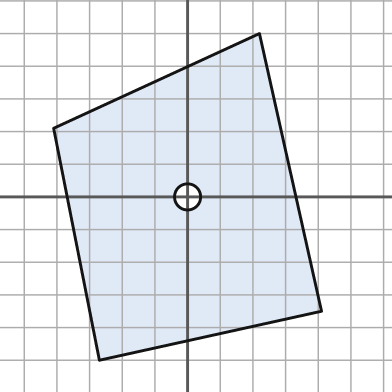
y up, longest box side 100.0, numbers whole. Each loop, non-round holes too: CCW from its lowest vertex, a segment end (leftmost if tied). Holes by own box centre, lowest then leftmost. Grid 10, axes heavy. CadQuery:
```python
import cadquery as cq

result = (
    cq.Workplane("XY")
    .moveTo(-27.0, -50.0)
    .lineTo(41.0, -35.0)
    .lineTo(22.0, 50.0)
    .lineTo(-41.0, 21.0)
    .close()
    .moveTo(0.0, 0.0)
    .circle(4.0)
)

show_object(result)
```